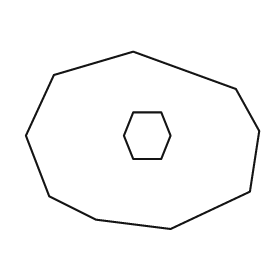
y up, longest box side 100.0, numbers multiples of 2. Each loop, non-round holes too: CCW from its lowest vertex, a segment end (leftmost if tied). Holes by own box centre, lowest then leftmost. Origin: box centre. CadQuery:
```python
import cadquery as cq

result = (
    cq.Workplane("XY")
    .moveTo(12.0, -38.0)
    .lineTo(46.0, -22.0)
    .lineTo(50.0, 4.0)
    .lineTo(40.0, 22.0)
    .lineTo(-4.0, 38.0)
    .lineTo(-38.0, 28.0)
    .lineTo(-50.0, 2.0)
    .lineTo(-40.0, -24.0)
    .lineTo(-20.0, -34.0)
    .close()
    .moveTo(-4.0, -8.0)
    .lineTo(8.0, -8.0)
    .lineTo(12.0, 2.0)
    .lineTo(8.0, 12.0)
    .lineTo(-4.0, 12.0)
    .lineTo(-8.0, 2.0)
    .close()
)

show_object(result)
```